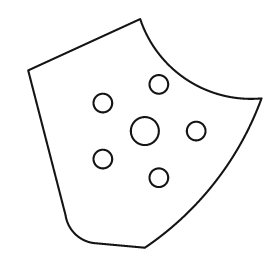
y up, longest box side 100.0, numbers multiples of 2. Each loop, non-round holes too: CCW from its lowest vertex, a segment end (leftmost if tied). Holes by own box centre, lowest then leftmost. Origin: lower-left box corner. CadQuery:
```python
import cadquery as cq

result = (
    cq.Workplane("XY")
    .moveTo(50.0, 0.0)
    .threePointArc((80.0, 28.0), (100.0, 64.0))
    .threePointArc((68.0, 72.0), (48.0, 98.0))
    .lineTo(0.0, 76.0)
    .lineTo(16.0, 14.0)
    .threePointArc((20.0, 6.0), (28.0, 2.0))
    .close()
    .moveTo(56.0, 30.0)
    .circle(4.0)
    .moveTo(32.0, 38.0)
    .circle(4.0)
    .moveTo(50.0, 50.0)
    .circle(6.0)
    .moveTo(72.0, 50.0)
    .circle(4.0)
    .moveTo(32.0, 62.0)
    .circle(4.0)
    .moveTo(56.0, 70.0)
    .circle(4.0)
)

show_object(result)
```